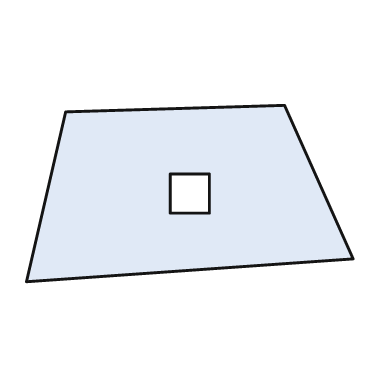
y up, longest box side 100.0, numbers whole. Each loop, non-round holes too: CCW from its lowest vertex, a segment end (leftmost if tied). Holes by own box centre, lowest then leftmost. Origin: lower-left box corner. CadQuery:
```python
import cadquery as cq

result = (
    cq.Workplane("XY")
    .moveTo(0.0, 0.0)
    .lineTo(100.0, 7.0)
    .lineTo(79.0, 54.0)
    .lineTo(12.0, 52.0)
    .close()
    .moveTo(44.0, 21.0)
    .lineTo(56.0, 21.0)
    .lineTo(56.0, 33.0)
    .lineTo(44.0, 33.0)
    .close()
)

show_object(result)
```